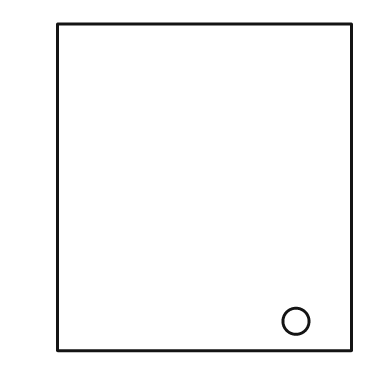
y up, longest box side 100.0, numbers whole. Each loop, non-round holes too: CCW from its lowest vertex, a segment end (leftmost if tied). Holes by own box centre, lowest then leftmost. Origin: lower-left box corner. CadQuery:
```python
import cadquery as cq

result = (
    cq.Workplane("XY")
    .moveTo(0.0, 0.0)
    .lineTo(90.0, 0.0)
    .lineTo(90.0, 100.0)
    .lineTo(0.0, 100.0)
    .close()
    .moveTo(73.0, 9.0)
    .circle(4.0)
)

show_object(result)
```